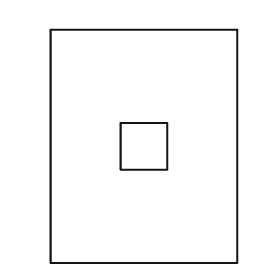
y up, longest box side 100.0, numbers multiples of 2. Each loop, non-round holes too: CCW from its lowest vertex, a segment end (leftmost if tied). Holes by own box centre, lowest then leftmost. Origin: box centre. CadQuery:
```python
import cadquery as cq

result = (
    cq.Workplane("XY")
    .moveTo(-40.0, -50.0)
    .lineTo(40.0, -50.0)
    .lineTo(40.0, 50.0)
    .lineTo(-40.0, 50.0)
    .close()
    .moveTo(-10.0, -10.0)
    .lineTo(10.0, -10.0)
    .lineTo(10.0, 10.0)
    .lineTo(-10.0, 10.0)
    .close()
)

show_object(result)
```